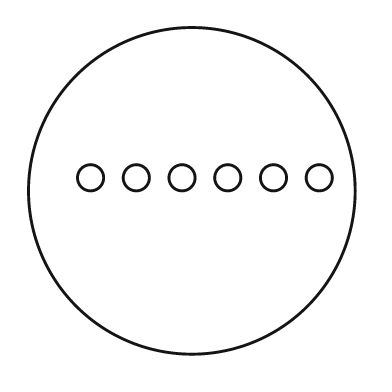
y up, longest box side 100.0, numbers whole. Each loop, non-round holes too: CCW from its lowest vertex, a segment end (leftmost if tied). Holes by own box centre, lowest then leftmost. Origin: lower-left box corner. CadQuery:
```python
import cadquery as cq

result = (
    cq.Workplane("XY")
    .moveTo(50.0, 50.0)
    .circle(50.0)
    .moveTo(19.0, 54.0)
    .circle(4.0)
    .moveTo(33.0, 54.0)
    .circle(4.0)
    .moveTo(47.0, 54.0)
    .circle(4.0)
    .moveTo(61.0, 54.0)
    .circle(4.0)
    .moveTo(75.0, 54.0)
    .circle(4.0)
    .moveTo(89.0, 54.0)
    .circle(4.0)
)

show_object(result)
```